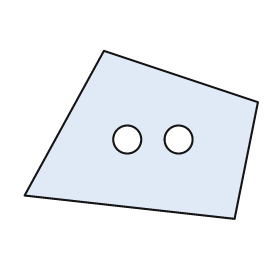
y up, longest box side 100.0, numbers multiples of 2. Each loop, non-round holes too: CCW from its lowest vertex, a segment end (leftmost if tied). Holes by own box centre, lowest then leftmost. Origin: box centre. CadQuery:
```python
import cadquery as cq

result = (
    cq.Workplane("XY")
    .moveTo(40.0, -36.0)
    .lineTo(50.0, 14.0)
    .lineTo(-16.0, 36.0)
    .lineTo(-50.0, -26.0)
    .close()
    .moveTo(-6.0, -2.0)
    .circle(6.0)
    .moveTo(16.0, -2.0)
    .circle(6.0)
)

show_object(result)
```